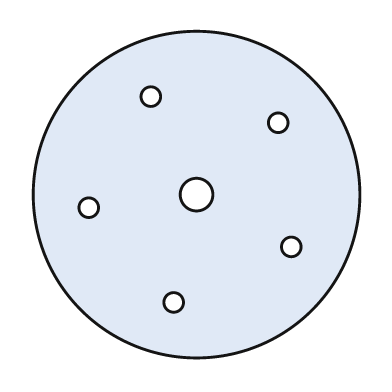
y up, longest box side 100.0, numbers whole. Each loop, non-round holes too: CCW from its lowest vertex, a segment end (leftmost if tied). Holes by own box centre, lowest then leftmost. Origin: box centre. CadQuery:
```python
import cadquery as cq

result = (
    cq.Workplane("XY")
    .moveTo(0.0, 0.0)
    .circle(50.0)
    .moveTo(-7.0, -33.0)
    .circle(3.0)
    .moveTo(29.0, -16.0)
    .circle(3.0)
    .moveTo(-33.0, -4.0)
    .circle(3.0)
    .moveTo(0.0, 0.0)
    .circle(5.0)
    .moveTo(25.0, 22.0)
    .circle(3.0)
    .moveTo(-14.0, 30.0)
    .circle(3.0)
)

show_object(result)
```